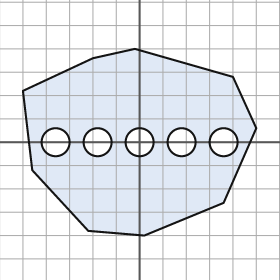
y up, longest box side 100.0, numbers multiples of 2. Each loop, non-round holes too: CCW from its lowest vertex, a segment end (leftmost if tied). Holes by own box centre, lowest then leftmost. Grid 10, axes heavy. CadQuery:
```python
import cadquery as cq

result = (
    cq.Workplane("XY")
    .moveTo(2.0, -40.0)
    .lineTo(36.0, -26.0)
    .lineTo(50.0, 6.0)
    .lineTo(40.0, 28.0)
    .lineTo(-2.0, 40.0)
    .lineTo(-20.0, 36.0)
    .lineTo(-50.0, 22.0)
    .lineTo(-46.0, -12.0)
    .lineTo(-22.0, -38.0)
    .close()
    .moveTo(-36.0, 0.0)
    .circle(6.0)
    .moveTo(-18.0, 0.0)
    .circle(6.0)
    .moveTo(0.0, 0.0)
    .circle(6.0)
    .moveTo(18.0, 0.0)
    .circle(6.0)
    .moveTo(36.0, 0.0)
    .circle(6.0)
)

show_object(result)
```